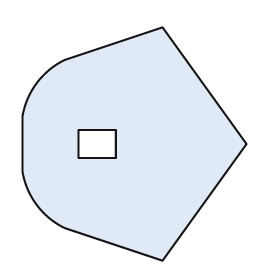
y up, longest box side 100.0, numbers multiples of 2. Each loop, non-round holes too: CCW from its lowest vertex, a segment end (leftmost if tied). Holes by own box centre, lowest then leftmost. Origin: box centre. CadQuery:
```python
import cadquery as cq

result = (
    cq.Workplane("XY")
    .moveTo(12.0, -50.0)
    .lineTo(48.0, 0.0)
    .lineTo(12.0, 50.0)
    .lineTo(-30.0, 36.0)
    .threePointArc((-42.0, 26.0), (-48.0, 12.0))
    .lineTo(-48.0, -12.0)
    .threePointArc((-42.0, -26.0), (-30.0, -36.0))
    .close()
    .moveTo(-24.0, -6.0)
    .lineTo(-8.0, -6.0)
    .lineTo(-8.0, 6.0)
    .lineTo(-24.0, 6.0)
    .close()
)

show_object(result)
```